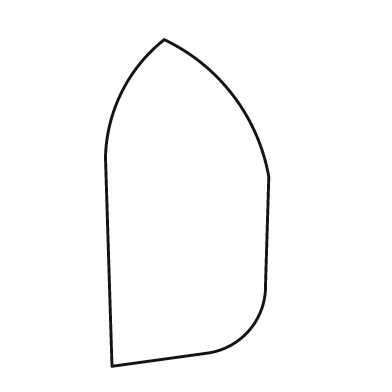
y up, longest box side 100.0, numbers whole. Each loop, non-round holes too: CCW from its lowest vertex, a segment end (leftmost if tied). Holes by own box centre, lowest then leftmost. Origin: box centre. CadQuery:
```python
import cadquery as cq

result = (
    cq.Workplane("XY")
    .moveTo(-23.0, -50.0)
    .lineTo(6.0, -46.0)
    .threePointArc((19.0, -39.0), (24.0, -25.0))
    .lineTo(25.0, 8.0)
    .threePointArc((14.0, 33.0), (-7.0, 50.0))
    .threePointArc((-20.0, 34.0), (-25.0, 14.0))
    .close()
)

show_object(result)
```